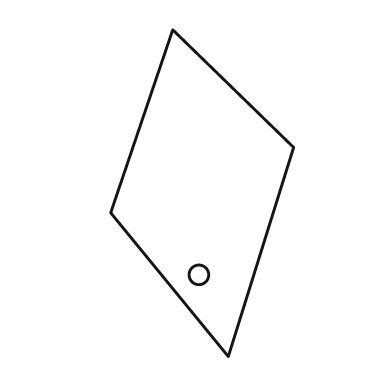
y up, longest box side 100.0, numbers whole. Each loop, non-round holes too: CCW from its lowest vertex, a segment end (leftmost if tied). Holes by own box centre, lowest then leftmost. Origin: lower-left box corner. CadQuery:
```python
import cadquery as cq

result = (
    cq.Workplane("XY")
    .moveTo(36.0, 0.0)
    .lineTo(56.0, 64.0)
    .lineTo(19.0, 100.0)
    .lineTo(0.0, 44.0)
    .close()
    .moveTo(27.0, 25.0)
    .circle(3.0)
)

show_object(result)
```